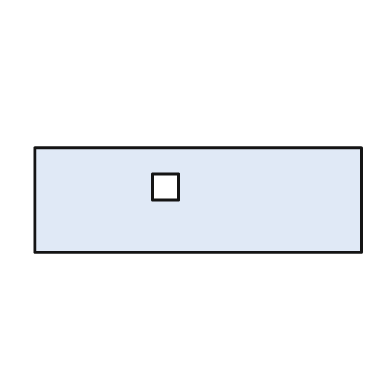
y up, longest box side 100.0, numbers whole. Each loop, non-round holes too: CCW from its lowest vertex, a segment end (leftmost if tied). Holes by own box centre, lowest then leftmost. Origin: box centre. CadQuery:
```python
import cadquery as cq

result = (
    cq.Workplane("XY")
    .moveTo(-50.0, -16.0)
    .lineTo(50.0, -16.0)
    .lineTo(50.0, 16.0)
    .lineTo(-50.0, 16.0)
    .close()
    .moveTo(-14.0, 0.0)
    .lineTo(-6.0, 0.0)
    .lineTo(-6.0, 8.0)
    .lineTo(-14.0, 8.0)
    .close()
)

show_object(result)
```